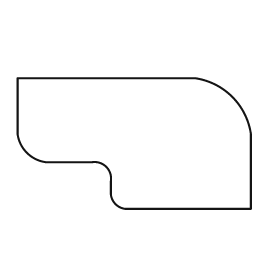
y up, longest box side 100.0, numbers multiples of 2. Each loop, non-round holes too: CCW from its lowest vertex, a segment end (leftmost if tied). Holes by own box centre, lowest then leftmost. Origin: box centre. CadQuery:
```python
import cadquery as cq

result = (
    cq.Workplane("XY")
    .moveTo(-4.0, -28.0)
    .lineTo(50.0, -28.0)
    .lineTo(50.0, 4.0)
    .threePointArc((42.0, 20.0), (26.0, 28.0))
    .lineTo(-50.0, 28.0)
    .lineTo(-50.0, 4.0)
    .threePointArc((-46.0, -4.0), (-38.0, -8.0))
    .lineTo(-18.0, -8.0)
    .threePointArc((-12.0, -10.0), (-10.0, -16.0))
    .lineTo(-10.0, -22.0)
    .threePointArc((-8.0, -26.0), (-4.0, -28.0))
    .close()
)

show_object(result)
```